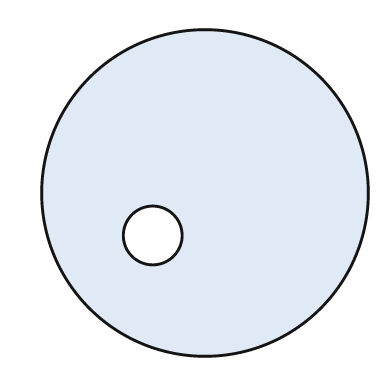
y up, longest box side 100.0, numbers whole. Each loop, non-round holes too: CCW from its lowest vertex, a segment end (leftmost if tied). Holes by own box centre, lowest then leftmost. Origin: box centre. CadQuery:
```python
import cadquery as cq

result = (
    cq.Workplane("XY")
    .moveTo(0.0, 0.0)
    .circle(50.0)
    .moveTo(-16.0, -13.0)
    .circle(9.0)
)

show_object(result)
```